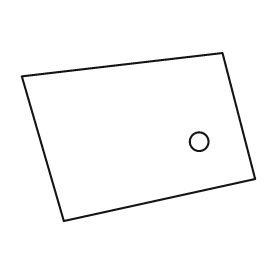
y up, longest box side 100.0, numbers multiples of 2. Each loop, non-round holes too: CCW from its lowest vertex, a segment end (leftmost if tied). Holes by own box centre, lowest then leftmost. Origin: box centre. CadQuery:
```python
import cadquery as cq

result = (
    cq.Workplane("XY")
    .moveTo(-32.0, -36.0)
    .lineTo(50.0, -18.0)
    .lineTo(36.0, 36.0)
    .lineTo(-50.0, 26.0)
    .close()
    .moveTo(26.0, -2.0)
    .circle(4.0)
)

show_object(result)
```